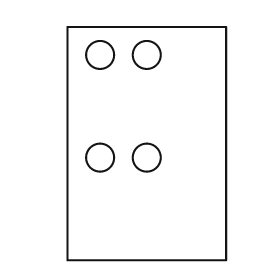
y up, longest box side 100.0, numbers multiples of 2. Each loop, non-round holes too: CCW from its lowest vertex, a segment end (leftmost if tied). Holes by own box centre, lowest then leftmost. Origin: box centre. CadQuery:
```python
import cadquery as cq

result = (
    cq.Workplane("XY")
    .moveTo(-34.0, -50.0)
    .lineTo(34.0, -50.0)
    .lineTo(34.0, 50.0)
    .lineTo(-34.0, 50.0)
    .close()
    .moveTo(-20.0, -6.0)
    .circle(6.0)
    .moveTo(0.0, -6.0)
    .circle(6.0)
    .moveTo(-20.0, 38.0)
    .circle(6.0)
    .moveTo(0.0, 38.0)
    .circle(6.0)
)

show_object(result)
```